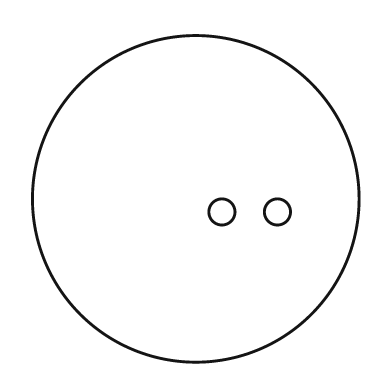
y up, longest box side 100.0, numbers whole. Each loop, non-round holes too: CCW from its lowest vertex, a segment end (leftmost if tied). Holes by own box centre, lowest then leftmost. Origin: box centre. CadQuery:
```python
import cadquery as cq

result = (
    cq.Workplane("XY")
    .moveTo(0.0, 0.0)
    .circle(50.0)
    .moveTo(8.0, -4.0)
    .circle(4.0)
    .moveTo(25.0, -4.0)
    .circle(4.0)
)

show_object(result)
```